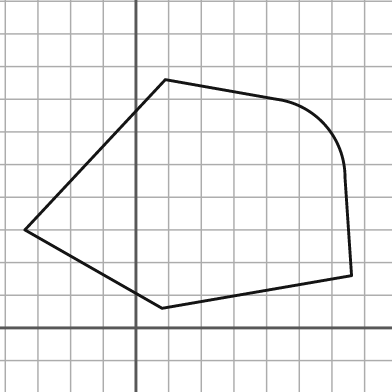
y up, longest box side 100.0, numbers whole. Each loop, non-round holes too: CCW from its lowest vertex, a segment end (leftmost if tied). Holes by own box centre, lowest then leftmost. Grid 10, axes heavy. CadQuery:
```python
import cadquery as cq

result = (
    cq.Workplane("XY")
    .moveTo(8.0, 6.0)
    .lineTo(66.0, 16.0)
    .lineTo(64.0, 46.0)
    .threePointArc((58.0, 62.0), (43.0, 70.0))
    .lineTo(9.0, 76.0)
    .lineTo(-34.0, 30.0)
    .close()
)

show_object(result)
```